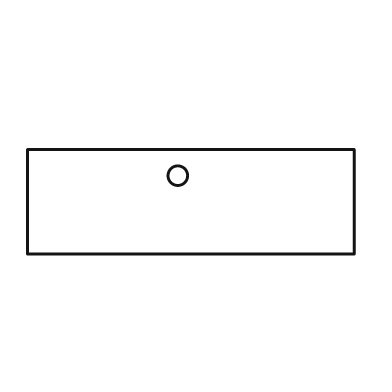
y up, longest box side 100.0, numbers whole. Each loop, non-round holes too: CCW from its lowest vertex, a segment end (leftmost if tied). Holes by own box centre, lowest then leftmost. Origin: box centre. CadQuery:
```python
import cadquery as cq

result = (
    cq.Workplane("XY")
    .moveTo(-50.0, -16.0)
    .lineTo(50.0, -16.0)
    .lineTo(50.0, 16.0)
    .lineTo(-50.0, 16.0)
    .close()
    .moveTo(-4.0, 8.0)
    .circle(3.0)
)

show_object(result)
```